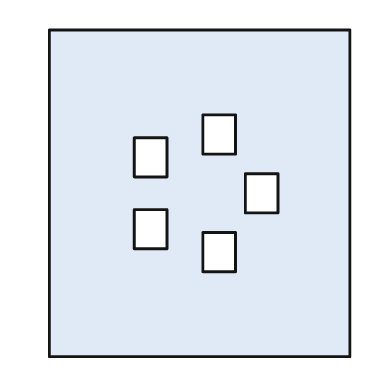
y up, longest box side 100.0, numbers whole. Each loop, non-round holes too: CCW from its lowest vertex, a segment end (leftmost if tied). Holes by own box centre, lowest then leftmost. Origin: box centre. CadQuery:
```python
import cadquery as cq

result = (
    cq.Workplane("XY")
    .moveTo(-46.0, -50.0)
    .lineTo(46.0, -50.0)
    .lineTo(46.0, 50.0)
    .lineTo(-46.0, 50.0)
    .close()
    .moveTo(1.0, -24.0)
    .lineTo(11.0, -24.0)
    .lineTo(11.0, -12.0)
    .lineTo(1.0, -12.0)
    .close()
    .moveTo(-20.0, -17.0)
    .lineTo(-10.0, -17.0)
    .lineTo(-10.0, -5.0)
    .lineTo(-20.0, -5.0)
    .close()
    .moveTo(14.0, -6.0)
    .lineTo(24.0, -6.0)
    .lineTo(24.0, 6.0)
    .lineTo(14.0, 6.0)
    .close()
    .moveTo(-20.0, 5.0)
    .lineTo(-10.0, 5.0)
    .lineTo(-10.0, 17.0)
    .lineTo(-20.0, 17.0)
    .close()
    .moveTo(1.0, 12.0)
    .lineTo(11.0, 12.0)
    .lineTo(11.0, 24.0)
    .lineTo(1.0, 24.0)
    .close()
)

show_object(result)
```